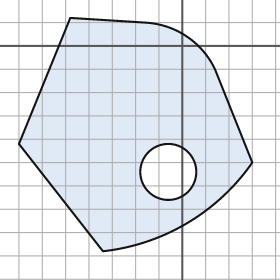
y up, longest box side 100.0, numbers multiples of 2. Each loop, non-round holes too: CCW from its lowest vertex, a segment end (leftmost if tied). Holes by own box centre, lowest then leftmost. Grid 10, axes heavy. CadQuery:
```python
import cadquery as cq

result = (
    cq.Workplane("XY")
    .moveTo(-34.0, -88.0)
    .threePointArc((2.0, -76.0), (30.0, -50.0))
    .lineTo(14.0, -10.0)
    .threePointArc((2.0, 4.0), (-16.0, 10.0))
    .lineTo(-48.0, 12.0)
    .lineTo(-70.0, -42.0)
    .close()
    .moveTo(-6.0, -54.0)
    .circle(12.0)
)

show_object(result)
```